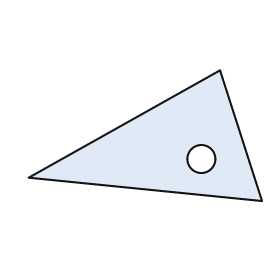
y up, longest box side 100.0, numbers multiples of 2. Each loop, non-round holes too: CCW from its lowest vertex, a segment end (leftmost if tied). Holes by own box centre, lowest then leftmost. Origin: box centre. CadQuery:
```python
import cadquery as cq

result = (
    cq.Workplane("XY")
    .moveTo(50.0, -28.0)
    .lineTo(32.0, 28.0)
    .lineTo(-50.0, -18.0)
    .close()
    .moveTo(24.0, -10.0)
    .circle(6.0)
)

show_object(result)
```